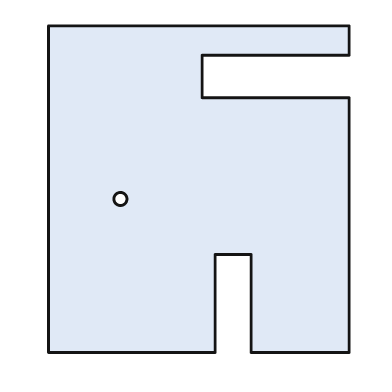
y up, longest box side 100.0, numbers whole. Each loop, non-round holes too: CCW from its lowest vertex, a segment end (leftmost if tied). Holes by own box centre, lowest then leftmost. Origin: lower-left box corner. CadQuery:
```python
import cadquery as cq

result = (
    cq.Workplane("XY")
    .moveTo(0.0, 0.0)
    .lineTo(51.0, 0.0)
    .lineTo(51.0, 30.0)
    .lineTo(62.0, 30.0)
    .lineTo(62.0, 0.0)
    .lineTo(92.0, 0.0)
    .lineTo(92.0, 78.0)
    .lineTo(47.0, 78.0)
    .lineTo(47.0, 91.0)
    .lineTo(92.0, 91.0)
    .lineTo(92.0, 100.0)
    .lineTo(0.0, 100.0)
    .close()
    .moveTo(22.0, 47.0)
    .circle(2.0)
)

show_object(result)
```